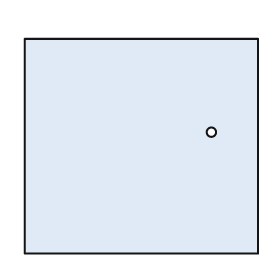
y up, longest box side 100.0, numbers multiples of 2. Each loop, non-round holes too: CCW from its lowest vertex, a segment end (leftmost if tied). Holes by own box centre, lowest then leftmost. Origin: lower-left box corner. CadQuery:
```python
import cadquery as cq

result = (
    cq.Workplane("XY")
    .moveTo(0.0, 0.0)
    .lineTo(100.0, 0.0)
    .lineTo(100.0, 92.0)
    .lineTo(0.0, 92.0)
    .close()
    .moveTo(80.0, 52.0)
    .circle(2.0)
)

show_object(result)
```